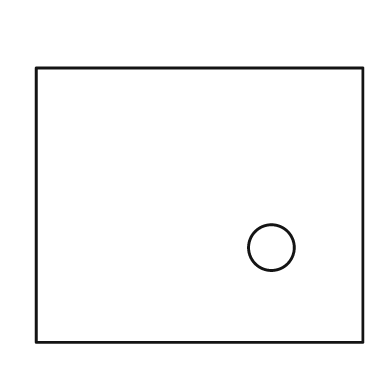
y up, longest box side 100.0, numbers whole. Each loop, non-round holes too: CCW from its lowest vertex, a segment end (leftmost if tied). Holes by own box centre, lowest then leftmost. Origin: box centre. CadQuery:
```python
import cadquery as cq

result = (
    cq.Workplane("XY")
    .moveTo(-50.0, -42.0)
    .lineTo(50.0, -42.0)
    .lineTo(50.0, 42.0)
    .lineTo(-50.0, 42.0)
    .close()
    .moveTo(22.0, -13.0)
    .circle(7.0)
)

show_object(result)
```